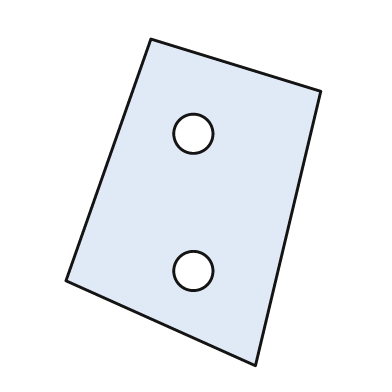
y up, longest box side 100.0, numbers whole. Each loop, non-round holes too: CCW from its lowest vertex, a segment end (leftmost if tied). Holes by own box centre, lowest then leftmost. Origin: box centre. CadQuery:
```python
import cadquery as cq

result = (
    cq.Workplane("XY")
    .moveTo(19.0, -50.0)
    .lineTo(39.0, 34.0)
    .lineTo(-13.0, 50.0)
    .lineTo(-39.0, -24.0)
    .close()
    .moveTo(0.0, -21.0)
    .circle(6.0)
    .moveTo(0.0, 21.0)
    .circle(6.0)
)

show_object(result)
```